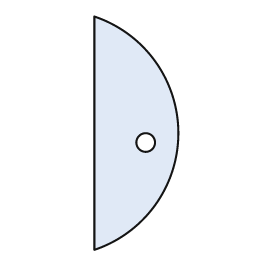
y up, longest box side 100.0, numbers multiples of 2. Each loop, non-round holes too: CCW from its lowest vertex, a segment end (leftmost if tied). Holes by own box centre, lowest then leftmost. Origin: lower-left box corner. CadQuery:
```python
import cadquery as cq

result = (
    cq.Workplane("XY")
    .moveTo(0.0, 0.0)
    .threePointArc((36.0, 50.0), (0.0, 100.0))
    .close()
    .moveTo(22.0, 46.0)
    .circle(4.0)
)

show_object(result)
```